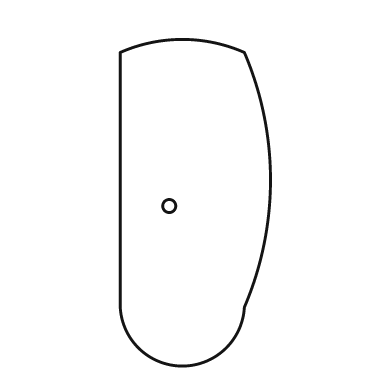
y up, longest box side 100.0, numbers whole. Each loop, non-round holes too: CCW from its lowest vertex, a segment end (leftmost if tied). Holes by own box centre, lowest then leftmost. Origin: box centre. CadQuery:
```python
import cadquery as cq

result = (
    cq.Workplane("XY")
    .moveTo(-23.0, -32.0)
    .threePointArc((-4.0, -50.0), (15.0, -32.0))
    .threePointArc((23.0, 7.0), (15.0, 46.0))
    .threePointArc((-4.0, 50.0), (-23.0, 46.0))
    .close()
    .moveTo(-8.0, -1.0)
    .circle(2.0)
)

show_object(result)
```